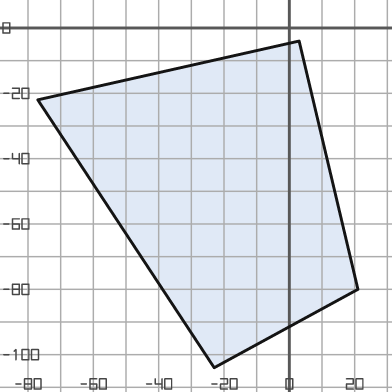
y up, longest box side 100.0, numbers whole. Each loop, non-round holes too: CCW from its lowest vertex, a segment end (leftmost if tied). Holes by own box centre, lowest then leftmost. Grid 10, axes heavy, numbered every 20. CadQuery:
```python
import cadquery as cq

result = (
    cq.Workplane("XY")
    .moveTo(-23.0, -104.0)
    .lineTo(21.0, -80.0)
    .lineTo(3.0, -4.0)
    .lineTo(-77.0, -22.0)
    .close()
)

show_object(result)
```